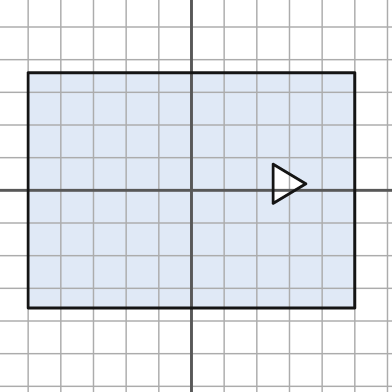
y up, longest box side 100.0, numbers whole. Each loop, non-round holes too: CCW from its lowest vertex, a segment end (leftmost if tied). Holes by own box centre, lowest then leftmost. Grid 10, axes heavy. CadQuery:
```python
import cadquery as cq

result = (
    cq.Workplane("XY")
    .moveTo(-50.0, -36.0)
    .lineTo(50.0, -36.0)
    .lineTo(50.0, 36.0)
    .lineTo(-50.0, 36.0)
    .close()
    .moveTo(25.0, -4.0)
    .lineTo(35.0, 2.0)
    .lineTo(25.0, 8.0)
    .close()
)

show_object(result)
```